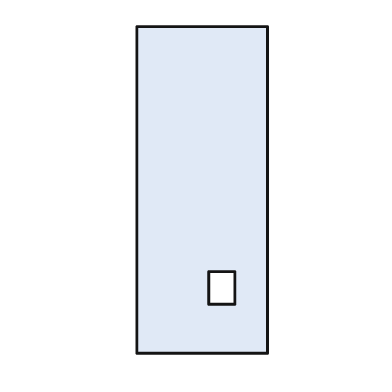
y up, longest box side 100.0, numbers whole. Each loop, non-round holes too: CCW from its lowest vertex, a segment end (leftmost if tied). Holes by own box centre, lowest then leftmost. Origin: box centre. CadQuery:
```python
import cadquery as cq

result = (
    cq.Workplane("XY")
    .moveTo(-20.0, -50.0)
    .lineTo(20.0, -50.0)
    .lineTo(20.0, 50.0)
    .lineTo(-20.0, 50.0)
    .close()
    .moveTo(2.0, -35.0)
    .lineTo(10.0, -35.0)
    .lineTo(10.0, -25.0)
    .lineTo(2.0, -25.0)
    .close()
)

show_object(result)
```